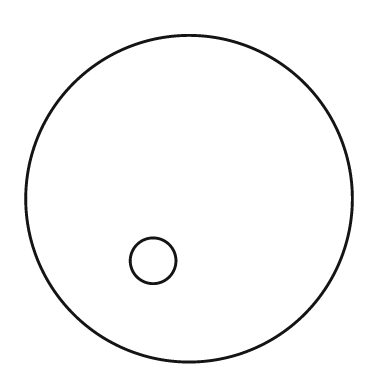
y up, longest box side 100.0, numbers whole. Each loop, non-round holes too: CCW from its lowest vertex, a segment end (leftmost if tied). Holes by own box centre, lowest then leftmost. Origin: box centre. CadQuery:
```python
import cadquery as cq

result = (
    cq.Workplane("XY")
    .moveTo(0.0, 0.0)
    .circle(50.0)
    .moveTo(-11.0, -19.0)
    .circle(7.0)
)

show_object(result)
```